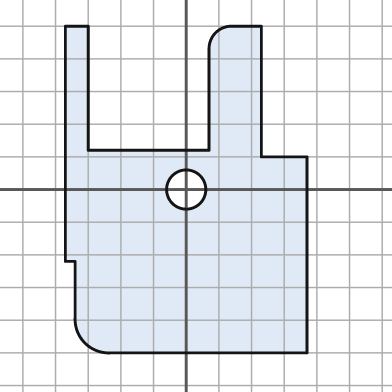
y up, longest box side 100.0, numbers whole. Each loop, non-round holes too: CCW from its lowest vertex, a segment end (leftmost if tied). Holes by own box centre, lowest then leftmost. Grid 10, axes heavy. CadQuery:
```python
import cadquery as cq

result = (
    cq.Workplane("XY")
    .moveTo(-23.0, -50.0)
    .lineTo(37.0, -50.0)
    .lineTo(37.0, 10.0)
    .lineTo(23.0, 10.0)
    .lineTo(23.0, 50.0)
    .lineTo(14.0, 50.0)
    .threePointArc((9.0, 48.0), (7.0, 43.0))
    .lineTo(7.0, 12.0)
    .lineTo(-30.0, 12.0)
    .lineTo(-30.0, 50.0)
    .lineTo(-37.0, 50.0)
    .lineTo(-37.0, -22.0)
    .lineTo(-34.0, -22.0)
    .lineTo(-34.0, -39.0)
    .threePointArc((-31.0, -47.0), (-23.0, -50.0))
    .close()
    .moveTo(0.0, 0.0)
    .circle(6.0)
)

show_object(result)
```